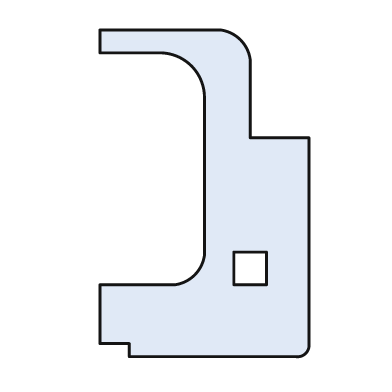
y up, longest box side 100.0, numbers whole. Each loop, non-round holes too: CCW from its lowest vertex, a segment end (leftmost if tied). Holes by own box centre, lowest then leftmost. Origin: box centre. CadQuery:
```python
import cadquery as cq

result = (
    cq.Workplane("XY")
    .moveTo(-23.0, -50.0)
    .lineTo(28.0, -50.0)
    .threePointArc((31.0, -49.0), (32.0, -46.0))
    .lineTo(32.0, 17.0)
    .lineTo(14.0, 17.0)
    .lineTo(14.0, 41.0)
    .threePointArc((11.0, 47.0), (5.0, 50.0))
    .lineTo(-32.0, 50.0)
    .lineTo(-32.0, 43.0)
    .lineTo(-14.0, 43.0)
    .threePointArc((-4.0, 39.0), (0.0, 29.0))
    .lineTo(0.0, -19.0)
    .threePointArc((-3.0, -25.0), (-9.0, -28.0))
    .lineTo(-32.0, -28.0)
    .lineTo(-32.0, -46.0)
    .lineTo(-23.0, -46.0)
    .close()
    .moveTo(9.0, -28.0)
    .lineTo(19.0, -28.0)
    .lineTo(19.0, -18.0)
    .lineTo(9.0, -18.0)
    .close()
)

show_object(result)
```